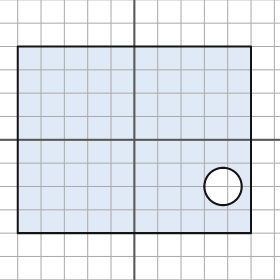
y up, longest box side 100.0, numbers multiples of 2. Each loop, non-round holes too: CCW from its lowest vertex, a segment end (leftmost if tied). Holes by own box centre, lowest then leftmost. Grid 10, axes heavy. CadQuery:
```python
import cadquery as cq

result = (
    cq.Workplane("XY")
    .moveTo(-50.0, -40.0)
    .lineTo(50.0, -40.0)
    .lineTo(50.0, 40.0)
    .lineTo(-50.0, 40.0)
    .close()
    .moveTo(38.0, -20.0)
    .circle(8.0)
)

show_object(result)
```